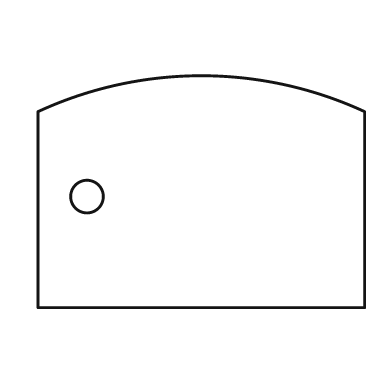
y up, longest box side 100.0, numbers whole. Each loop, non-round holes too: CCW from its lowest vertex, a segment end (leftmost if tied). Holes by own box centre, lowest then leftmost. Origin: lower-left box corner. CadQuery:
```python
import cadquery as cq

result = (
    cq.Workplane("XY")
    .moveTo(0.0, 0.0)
    .lineTo(100.0, 0.0)
    .lineTo(100.0, 60.0)
    .threePointArc((50.0, 71.0), (0.0, 60.0))
    .close()
    .moveTo(15.0, 34.0)
    .circle(5.0)
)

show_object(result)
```